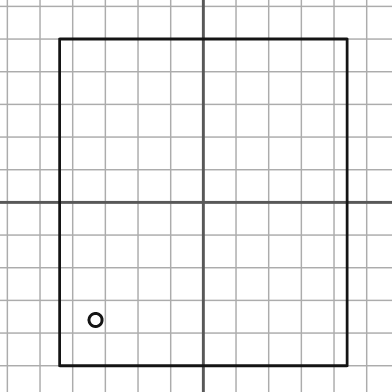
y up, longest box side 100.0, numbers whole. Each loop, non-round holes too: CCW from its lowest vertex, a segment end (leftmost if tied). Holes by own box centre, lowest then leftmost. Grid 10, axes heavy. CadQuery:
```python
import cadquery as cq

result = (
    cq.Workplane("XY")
    .moveTo(-44.0, -50.0)
    .lineTo(44.0, -50.0)
    .lineTo(44.0, 50.0)
    .lineTo(-44.0, 50.0)
    .close()
    .moveTo(-33.0, -36.0)
    .circle(2.0)
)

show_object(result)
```